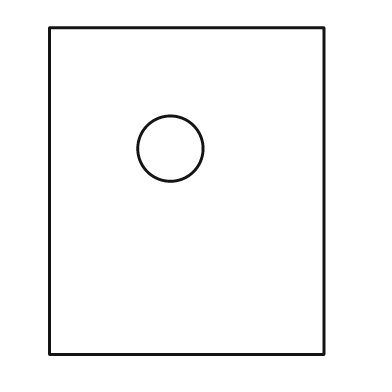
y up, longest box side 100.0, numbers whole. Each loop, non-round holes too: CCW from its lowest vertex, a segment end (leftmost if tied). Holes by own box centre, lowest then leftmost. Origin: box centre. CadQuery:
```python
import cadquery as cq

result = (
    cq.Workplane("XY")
    .moveTo(-42.0, -50.0)
    .lineTo(42.0, -50.0)
    .lineTo(42.0, 50.0)
    .lineTo(-42.0, 50.0)
    .close()
    .moveTo(-5.0, 13.0)
    .circle(10.0)
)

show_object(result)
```